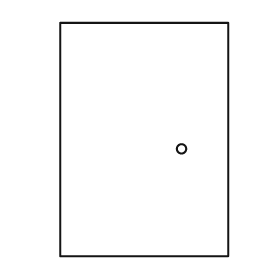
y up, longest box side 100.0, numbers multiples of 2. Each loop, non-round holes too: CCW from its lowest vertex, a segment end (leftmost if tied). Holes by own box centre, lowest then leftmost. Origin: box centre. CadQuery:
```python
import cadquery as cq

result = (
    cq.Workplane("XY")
    .moveTo(-36.0, -50.0)
    .lineTo(36.0, -50.0)
    .lineTo(36.0, 50.0)
    .lineTo(-36.0, 50.0)
    .close()
    .moveTo(16.0, -4.0)
    .circle(2.0)
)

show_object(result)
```